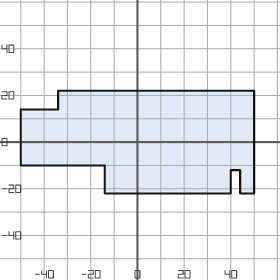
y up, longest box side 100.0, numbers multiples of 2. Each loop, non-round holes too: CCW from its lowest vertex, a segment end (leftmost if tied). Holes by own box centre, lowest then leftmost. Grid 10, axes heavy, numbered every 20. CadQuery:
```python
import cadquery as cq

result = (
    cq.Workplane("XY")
    .moveTo(-14.0, -22.0)
    .lineTo(40.0, -22.0)
    .lineTo(40.0, -12.0)
    .lineTo(44.0, -12.0)
    .lineTo(44.0, -22.0)
    .lineTo(50.0, -22.0)
    .lineTo(50.0, 22.0)
    .lineTo(-34.0, 22.0)
    .lineTo(-34.0, 14.0)
    .lineTo(-50.0, 14.0)
    .lineTo(-50.0, -10.0)
    .lineTo(-14.0, -10.0)
    .close()
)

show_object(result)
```